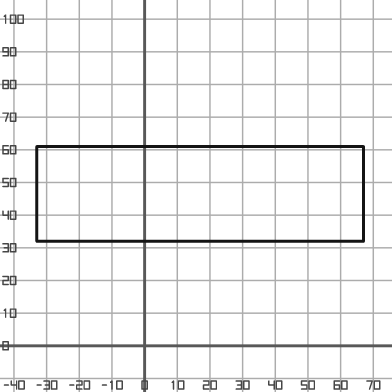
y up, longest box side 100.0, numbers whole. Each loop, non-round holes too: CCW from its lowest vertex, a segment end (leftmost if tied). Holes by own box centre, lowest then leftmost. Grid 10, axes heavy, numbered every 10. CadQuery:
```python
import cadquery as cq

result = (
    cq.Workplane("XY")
    .moveTo(-33.0, 32.0)
    .lineTo(67.0, 32.0)
    .lineTo(67.0, 61.0)
    .lineTo(-33.0, 61.0)
    .close()
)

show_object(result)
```